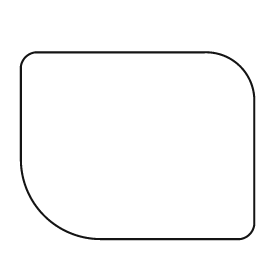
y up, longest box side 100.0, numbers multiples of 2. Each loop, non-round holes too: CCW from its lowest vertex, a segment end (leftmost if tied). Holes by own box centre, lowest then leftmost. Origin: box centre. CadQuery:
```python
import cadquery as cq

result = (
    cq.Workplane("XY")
    .moveTo(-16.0, -40.0)
    .lineTo(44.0, -40.0)
    .threePointArc((48.0, -38.0), (50.0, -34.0))
    .lineTo(50.0, 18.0)
    .threePointArc((44.0, 34.0), (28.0, 40.0))
    .lineTo(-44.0, 40.0)
    .threePointArc((-48.0, 38.0), (-50.0, 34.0))
    .lineTo(-50.0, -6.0)
    .threePointArc((-40.0, -30.0), (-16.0, -40.0))
    .close()
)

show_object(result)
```